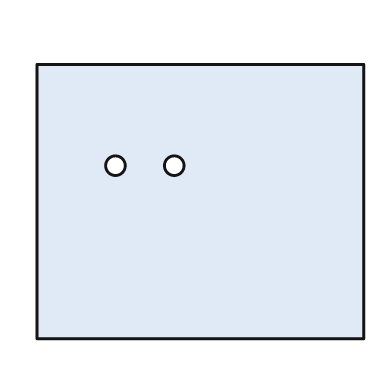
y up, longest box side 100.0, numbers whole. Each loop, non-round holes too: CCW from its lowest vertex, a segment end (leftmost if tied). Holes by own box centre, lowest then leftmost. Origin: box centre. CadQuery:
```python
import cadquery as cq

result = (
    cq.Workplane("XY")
    .moveTo(-50.0, -42.0)
    .lineTo(50.0, -42.0)
    .lineTo(50.0, 42.0)
    .lineTo(-50.0, 42.0)
    .close()
    .moveTo(-26.0, 11.0)
    .circle(3.0)
    .moveTo(-8.0, 11.0)
    .circle(3.0)
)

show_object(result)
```